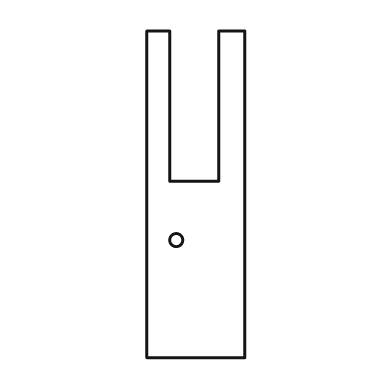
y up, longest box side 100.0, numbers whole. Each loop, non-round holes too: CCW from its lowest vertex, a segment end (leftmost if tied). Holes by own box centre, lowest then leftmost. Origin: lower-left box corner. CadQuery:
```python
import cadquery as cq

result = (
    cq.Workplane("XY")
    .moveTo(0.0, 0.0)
    .lineTo(30.0, 0.0)
    .lineTo(30.0, 100.0)
    .lineTo(22.0, 100.0)
    .lineTo(22.0, 54.0)
    .lineTo(7.0, 54.0)
    .lineTo(7.0, 100.0)
    .lineTo(0.0, 100.0)
    .close()
    .moveTo(9.0, 36.0)
    .circle(2.0)
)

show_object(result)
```